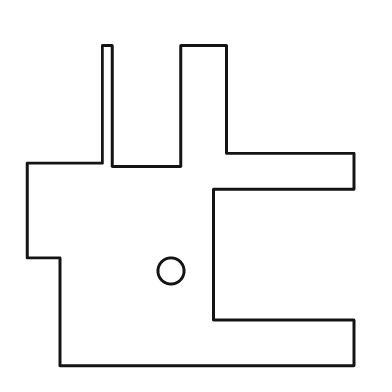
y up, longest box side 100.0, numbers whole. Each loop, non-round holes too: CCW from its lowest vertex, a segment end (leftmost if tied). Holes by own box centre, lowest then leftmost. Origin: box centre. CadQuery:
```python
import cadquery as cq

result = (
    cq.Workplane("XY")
    .moveTo(-40.0, -49.0)
    .lineTo(50.0, -49.0)
    .lineTo(50.0, -35.0)
    .lineTo(7.0, -35.0)
    .lineTo(7.0, 5.0)
    .lineTo(50.0, 5.0)
    .lineTo(50.0, 16.0)
    .lineTo(11.0, 16.0)
    .lineTo(11.0, 49.0)
    .lineTo(-3.0, 49.0)
    .lineTo(-3.0, 12.0)
    .lineTo(-24.0, 12.0)
    .lineTo(-24.0, 49.0)
    .lineTo(-27.0, 49.0)
    .lineTo(-27.0, 13.0)
    .lineTo(-50.0, 13.0)
    .lineTo(-50.0, -16.0)
    .lineTo(-40.0, -16.0)
    .close()
    .moveTo(-6.0, -20.0)
    .circle(4.0)
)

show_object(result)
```